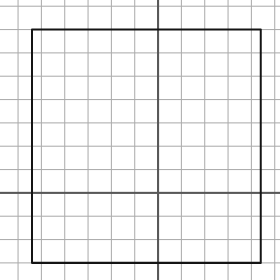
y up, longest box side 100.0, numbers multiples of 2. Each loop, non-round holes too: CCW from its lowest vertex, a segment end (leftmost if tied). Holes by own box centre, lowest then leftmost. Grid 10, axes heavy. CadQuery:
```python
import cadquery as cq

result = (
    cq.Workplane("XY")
    .moveTo(-54.0, -30.0)
    .lineTo(44.0, -30.0)
    .lineTo(44.0, 70.0)
    .lineTo(-54.0, 70.0)
    .close()
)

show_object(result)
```